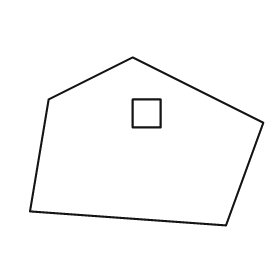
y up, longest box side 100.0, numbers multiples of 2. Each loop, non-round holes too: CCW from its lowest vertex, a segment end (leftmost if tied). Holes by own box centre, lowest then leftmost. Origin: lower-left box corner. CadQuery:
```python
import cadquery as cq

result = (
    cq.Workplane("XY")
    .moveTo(84.0, 0.0)
    .lineTo(100.0, 44.0)
    .lineTo(44.0, 72.0)
    .lineTo(8.0, 54.0)
    .lineTo(0.0, 6.0)
    .close()
    .moveTo(44.0, 42.0)
    .lineTo(56.0, 42.0)
    .lineTo(56.0, 54.0)
    .lineTo(44.0, 54.0)
    .close()
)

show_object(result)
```